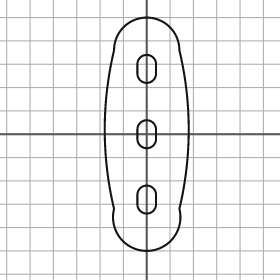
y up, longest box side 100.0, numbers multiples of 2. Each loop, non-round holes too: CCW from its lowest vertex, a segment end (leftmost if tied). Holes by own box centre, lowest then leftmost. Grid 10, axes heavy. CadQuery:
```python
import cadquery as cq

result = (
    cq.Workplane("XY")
    .moveTo(-14.0, -32.0)
    .threePointArc((0.0, -50.0), (14.0, -32.0))
    .threePointArc((18.0, 2.0), (14.0, 36.0))
    .threePointArc((0.0, 50.0), (-14.0, 36.0))
    .threePointArc((-18.0, 2.0), (-14.0, -32.0))
    .close()
    .moveTo(-4.0, -30.0)
    .threePointArc((0.0, -34.0), (4.0, -30.0))
    .lineTo(4.0, -26.0)
    .threePointArc((0.0, -22.0), (-4.0, -26.0))
    .close()
    .moveTo(-4.0, -2.0)
    .threePointArc((0.0, -6.0), (4.0, -2.0))
    .lineTo(4.0, 2.0)
    .threePointArc((0.0, 6.0), (-4.0, 2.0))
    .close()
    .moveTo(-4.0, 26.0)
    .threePointArc((0.0, 22.0), (4.0, 26.0))
    .lineTo(4.0, 30.0)
    .threePointArc((0.0, 34.0), (-4.0, 30.0))
    .close()
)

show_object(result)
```